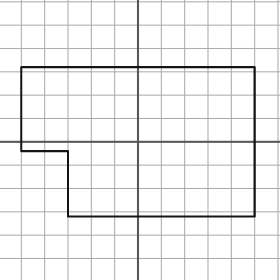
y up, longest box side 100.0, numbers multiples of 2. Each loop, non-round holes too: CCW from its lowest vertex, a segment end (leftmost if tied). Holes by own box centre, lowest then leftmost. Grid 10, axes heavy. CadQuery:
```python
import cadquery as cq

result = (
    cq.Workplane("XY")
    .moveTo(-30.0, -32.0)
    .lineTo(50.0, -32.0)
    .lineTo(50.0, 32.0)
    .lineTo(-50.0, 32.0)
    .lineTo(-50.0, -4.0)
    .lineTo(-30.0, -4.0)
    .close()
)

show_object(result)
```